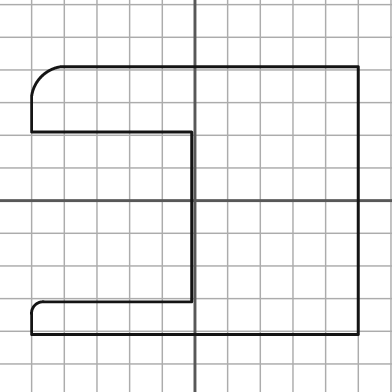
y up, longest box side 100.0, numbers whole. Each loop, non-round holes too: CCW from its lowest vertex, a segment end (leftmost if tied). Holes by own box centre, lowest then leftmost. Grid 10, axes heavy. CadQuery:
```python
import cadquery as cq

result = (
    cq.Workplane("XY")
    .moveTo(-50.0, -41.0)
    .lineTo(50.0, -41.0)
    .lineTo(50.0, 41.0)
    .lineTo(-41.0, 41.0)
    .threePointArc((-47.0, 38.0), (-50.0, 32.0))
    .lineTo(-50.0, 21.0)
    .lineTo(-1.0, 21.0)
    .lineTo(-1.0, -31.0)
    .lineTo(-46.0, -31.0)
    .threePointArc((-49.0, -32.0), (-50.0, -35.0))
    .close()
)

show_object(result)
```